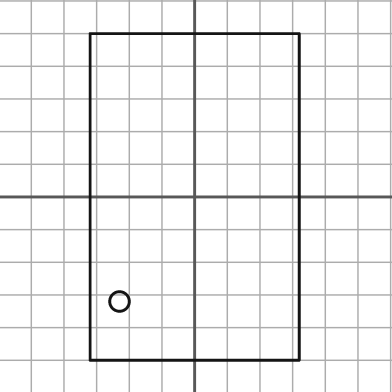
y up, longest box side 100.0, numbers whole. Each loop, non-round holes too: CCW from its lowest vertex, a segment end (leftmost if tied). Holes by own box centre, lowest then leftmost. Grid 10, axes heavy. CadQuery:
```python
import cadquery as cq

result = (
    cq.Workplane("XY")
    .moveTo(-32.0, -50.0)
    .lineTo(32.0, -50.0)
    .lineTo(32.0, 50.0)
    .lineTo(-32.0, 50.0)
    .close()
    .moveTo(-23.0, -32.0)
    .circle(3.0)
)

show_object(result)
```